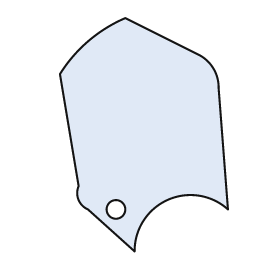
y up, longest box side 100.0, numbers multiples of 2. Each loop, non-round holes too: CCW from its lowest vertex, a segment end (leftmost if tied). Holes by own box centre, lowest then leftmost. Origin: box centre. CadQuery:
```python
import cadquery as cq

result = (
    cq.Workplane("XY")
    .moveTo(-4.0, -50.0)
    .threePointArc((10.0, -28.0), (36.0, -32.0))
    .lineTo(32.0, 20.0)
    .threePointArc((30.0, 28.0), (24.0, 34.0))
    .lineTo(-8.0, 50.0)
    .threePointArc((-24.0, 40.0), (-36.0, 26.0))
    .lineTo(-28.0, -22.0)
    .threePointArc((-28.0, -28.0), (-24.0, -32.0))
    .close()
    .moveTo(-12.0, -32.0)
    .circle(4.0)
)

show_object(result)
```